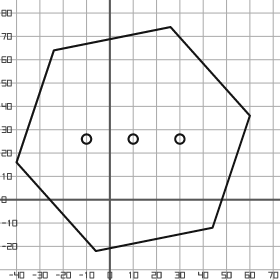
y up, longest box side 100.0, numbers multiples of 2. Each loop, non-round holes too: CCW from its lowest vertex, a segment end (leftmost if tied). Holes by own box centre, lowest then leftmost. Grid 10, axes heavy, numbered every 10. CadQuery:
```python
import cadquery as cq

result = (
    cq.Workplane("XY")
    .moveTo(-6.0, -22.0)
    .lineTo(44.0, -12.0)
    .lineTo(60.0, 36.0)
    .lineTo(26.0, 74.0)
    .lineTo(-24.0, 64.0)
    .lineTo(-40.0, 16.0)
    .close()
    .moveTo(-10.0, 26.0)
    .circle(2.0)
    .moveTo(10.0, 26.0)
    .circle(2.0)
    .moveTo(30.0, 26.0)
    .circle(2.0)
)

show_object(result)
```